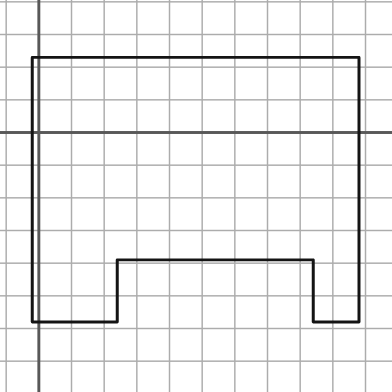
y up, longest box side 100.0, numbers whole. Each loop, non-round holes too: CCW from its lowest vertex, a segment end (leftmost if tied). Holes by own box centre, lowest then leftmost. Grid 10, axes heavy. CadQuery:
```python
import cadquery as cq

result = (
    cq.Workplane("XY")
    .moveTo(-2.0, -58.0)
    .lineTo(24.0, -58.0)
    .lineTo(24.0, -39.0)
    .lineTo(84.0, -39.0)
    .lineTo(84.0, -58.0)
    .lineTo(98.0, -58.0)
    .lineTo(98.0, 23.0)
    .lineTo(-2.0, 23.0)
    .close()
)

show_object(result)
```